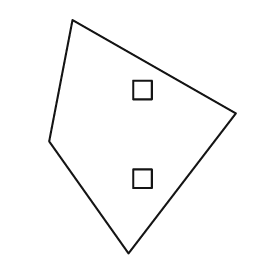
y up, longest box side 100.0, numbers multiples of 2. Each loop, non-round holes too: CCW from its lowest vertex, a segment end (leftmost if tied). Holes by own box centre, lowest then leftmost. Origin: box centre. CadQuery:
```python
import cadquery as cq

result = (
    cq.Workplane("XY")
    .moveTo(-6.0, -50.0)
    .lineTo(40.0, 10.0)
    .lineTo(-30.0, 50.0)
    .lineTo(-40.0, -2.0)
    .close()
    .moveTo(-4.0, -22.0)
    .lineTo(4.0, -22.0)
    .lineTo(4.0, -14.0)
    .lineTo(-4.0, -14.0)
    .close()
    .moveTo(-4.0, 16.0)
    .lineTo(4.0, 16.0)
    .lineTo(4.0, 24.0)
    .lineTo(-4.0, 24.0)
    .close()
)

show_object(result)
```